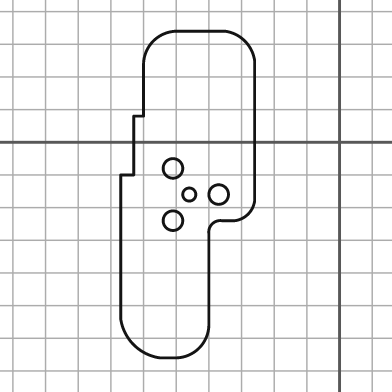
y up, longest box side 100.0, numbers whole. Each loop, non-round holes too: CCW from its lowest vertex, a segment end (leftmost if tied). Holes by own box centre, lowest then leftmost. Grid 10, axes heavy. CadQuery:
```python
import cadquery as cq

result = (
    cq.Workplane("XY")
    .moveTo(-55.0, -66.0)
    .lineTo(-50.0, -66.0)
    .threePointArc((-43.0, -63.0), (-40.0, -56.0))
    .lineTo(-40.0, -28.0)
    .threePointArc((-39.0, -25.0), (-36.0, -24.0))
    .lineTo(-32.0, -24.0)
    .threePointArc((-28.0, -22.0), (-26.0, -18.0))
    .lineTo(-26.0, 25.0)
    .threePointArc((-29.0, 31.0), (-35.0, 34.0))
    .lineTo(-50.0, 34.0)
    .threePointArc((-57.0, 31.0), (-60.0, 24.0))
    .lineTo(-60.0, 8.0)
    .lineTo(-63.0, 8.0)
    .lineTo(-63.0, -10.0)
    .lineTo(-67.0, -10.0)
    .lineTo(-67.0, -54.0)
    .threePointArc((-63.0, -62.0), (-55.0, -66.0))
    .close()
    .moveTo(-51.0, -24.0)
    .circle(3.0)
    .moveTo(-46.0, -16.0)
    .circle(2.0)
    .moveTo(-37.0, -16.0)
    .circle(3.0)
    .moveTo(-51.0, -8.0)
    .circle(3.0)
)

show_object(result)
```